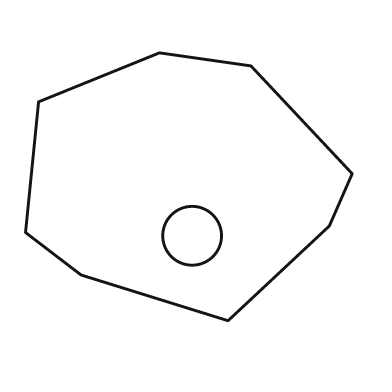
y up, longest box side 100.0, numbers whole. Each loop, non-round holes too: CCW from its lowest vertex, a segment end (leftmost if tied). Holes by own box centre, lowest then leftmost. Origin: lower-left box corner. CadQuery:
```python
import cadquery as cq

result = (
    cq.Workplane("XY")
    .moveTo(62.0, 0.0)
    .lineTo(93.0, 29.0)
    .lineTo(100.0, 45.0)
    .lineTo(69.0, 78.0)
    .lineTo(41.0, 82.0)
    .lineTo(4.0, 67.0)
    .lineTo(0.0, 27.0)
    .lineTo(17.0, 14.0)
    .close()
    .moveTo(51.0, 26.0)
    .circle(9.0)
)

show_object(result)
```